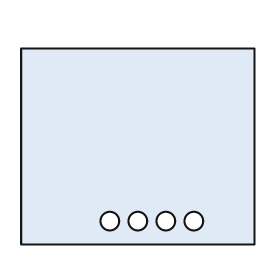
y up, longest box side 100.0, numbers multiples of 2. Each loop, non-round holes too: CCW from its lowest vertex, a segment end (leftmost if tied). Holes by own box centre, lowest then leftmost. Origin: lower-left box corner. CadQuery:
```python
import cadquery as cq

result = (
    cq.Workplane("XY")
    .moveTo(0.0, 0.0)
    .lineTo(100.0, 0.0)
    .lineTo(100.0, 84.0)
    .lineTo(0.0, 84.0)
    .close()
    .moveTo(38.0, 10.0)
    .circle(4.0)
    .moveTo(50.0, 10.0)
    .circle(4.0)
    .moveTo(62.0, 10.0)
    .circle(4.0)
    .moveTo(74.0, 10.0)
    .circle(4.0)
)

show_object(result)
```